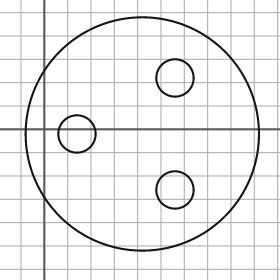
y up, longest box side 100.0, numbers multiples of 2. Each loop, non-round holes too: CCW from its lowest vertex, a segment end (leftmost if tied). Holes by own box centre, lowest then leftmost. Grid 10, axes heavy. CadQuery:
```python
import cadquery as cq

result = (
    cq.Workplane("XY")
    .moveTo(42.0, -2.0)
    .circle(50.0)
    .moveTo(56.0, -26.0)
    .circle(8.0)
    .moveTo(14.0, -2.0)
    .circle(8.0)
    .moveTo(56.0, 22.0)
    .circle(8.0)
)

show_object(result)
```